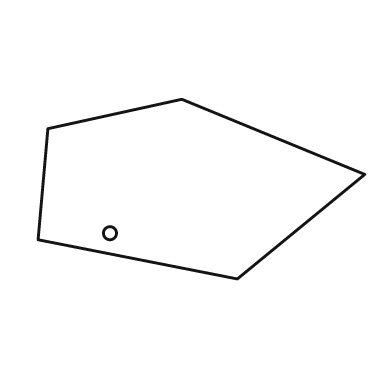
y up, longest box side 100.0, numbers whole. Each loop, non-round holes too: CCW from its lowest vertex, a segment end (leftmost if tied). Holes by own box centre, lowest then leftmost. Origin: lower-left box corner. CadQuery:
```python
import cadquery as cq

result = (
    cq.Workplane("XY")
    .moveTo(61.0, 0.0)
    .lineTo(100.0, 32.0)
    .lineTo(44.0, 55.0)
    .lineTo(3.0, 46.0)
    .lineTo(0.0, 12.0)
    .close()
    .moveTo(22.0, 14.0)
    .circle(2.0)
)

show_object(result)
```